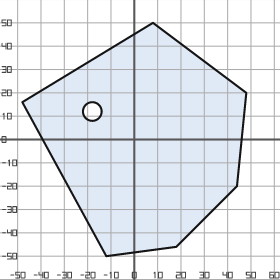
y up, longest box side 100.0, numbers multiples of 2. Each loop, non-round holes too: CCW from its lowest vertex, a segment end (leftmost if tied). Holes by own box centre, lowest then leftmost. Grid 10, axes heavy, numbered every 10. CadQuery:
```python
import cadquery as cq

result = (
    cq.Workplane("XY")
    .moveTo(-12.0, -50.0)
    .lineTo(18.0, -46.0)
    .lineTo(44.0, -20.0)
    .lineTo(48.0, 20.0)
    .lineTo(8.0, 50.0)
    .lineTo(-48.0, 16.0)
    .close()
    .moveTo(-18.0, 12.0)
    .circle(4.0)
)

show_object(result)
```